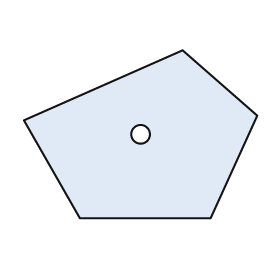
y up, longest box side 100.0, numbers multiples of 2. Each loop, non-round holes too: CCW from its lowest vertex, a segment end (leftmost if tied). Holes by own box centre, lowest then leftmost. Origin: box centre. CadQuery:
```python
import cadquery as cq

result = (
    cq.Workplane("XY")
    .moveTo(-26.0, -36.0)
    .lineTo(30.0, -36.0)
    .lineTo(50.0, 8.0)
    .lineTo(18.0, 36.0)
    .lineTo(-50.0, 6.0)
    .close()
    .moveTo(0.0, 0.0)
    .circle(4.0)
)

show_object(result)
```